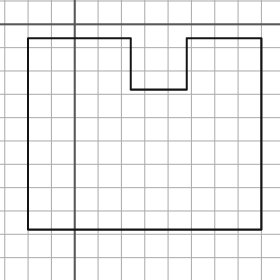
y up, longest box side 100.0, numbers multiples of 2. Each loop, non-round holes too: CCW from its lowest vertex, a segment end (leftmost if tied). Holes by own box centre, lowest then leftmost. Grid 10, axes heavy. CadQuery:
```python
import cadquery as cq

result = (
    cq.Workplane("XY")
    .moveTo(-20.0, -88.0)
    .lineTo(80.0, -88.0)
    .lineTo(80.0, -6.0)
    .lineTo(48.0, -6.0)
    .lineTo(48.0, -28.0)
    .lineTo(24.0, -28.0)
    .lineTo(24.0, -6.0)
    .lineTo(-20.0, -6.0)
    .close()
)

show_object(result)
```